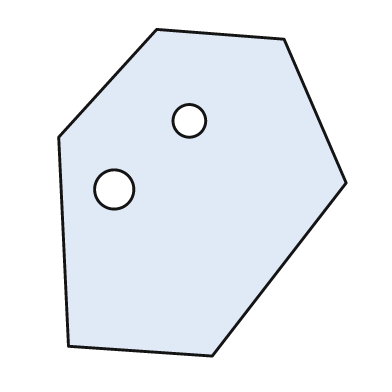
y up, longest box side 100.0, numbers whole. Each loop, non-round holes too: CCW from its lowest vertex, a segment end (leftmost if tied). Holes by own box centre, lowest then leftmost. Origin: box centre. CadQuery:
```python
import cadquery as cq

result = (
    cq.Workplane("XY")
    .moveTo(3.0, -50.0)
    .lineTo(44.0, 3.0)
    .lineTo(25.0, 47.0)
    .lineTo(-14.0, 50.0)
    .lineTo(-44.0, 17.0)
    .lineTo(-41.0, -47.0)
    .close()
    .moveTo(-27.0, 1.0)
    .circle(6.0)
    .moveTo(-4.0, 22.0)
    .circle(5.0)
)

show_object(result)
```